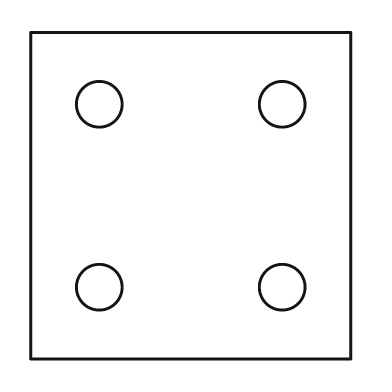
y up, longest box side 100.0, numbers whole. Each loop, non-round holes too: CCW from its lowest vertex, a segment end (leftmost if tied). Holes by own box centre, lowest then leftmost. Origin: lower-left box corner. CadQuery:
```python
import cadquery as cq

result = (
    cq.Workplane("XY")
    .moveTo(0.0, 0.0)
    .lineTo(98.0, 0.0)
    .lineTo(98.0, 100.0)
    .lineTo(0.0, 100.0)
    .close()
    .moveTo(21.0, 22.0)
    .circle(7.0)
    .moveTo(77.0, 22.0)
    .circle(7.0)
    .moveTo(21.0, 78.0)
    .circle(7.0)
    .moveTo(77.0, 78.0)
    .circle(7.0)
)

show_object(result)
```